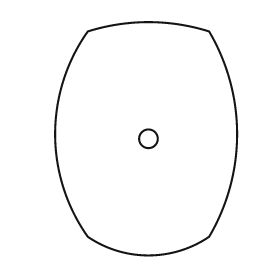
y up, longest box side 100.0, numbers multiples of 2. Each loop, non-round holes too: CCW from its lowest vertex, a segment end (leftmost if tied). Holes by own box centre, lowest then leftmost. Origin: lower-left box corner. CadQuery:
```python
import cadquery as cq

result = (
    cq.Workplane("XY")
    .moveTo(14.0, 8.0)
    .threePointArc((40.0, 0.0), (66.0, 8.0))
    .threePointArc((78.0, 52.0), (66.0, 96.0))
    .threePointArc((40.0, 100.0), (14.0, 96.0))
    .threePointArc((0.0, 52.0), (14.0, 8.0))
    .close()
    .moveTo(40.0, 50.0)
    .circle(4.0)
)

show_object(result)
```